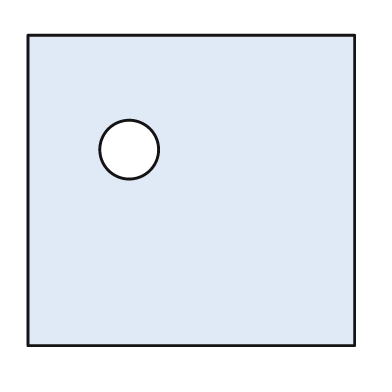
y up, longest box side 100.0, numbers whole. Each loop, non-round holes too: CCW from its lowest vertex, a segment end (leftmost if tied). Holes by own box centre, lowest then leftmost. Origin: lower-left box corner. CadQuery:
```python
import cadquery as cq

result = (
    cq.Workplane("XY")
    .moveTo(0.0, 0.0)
    .lineTo(100.0, 0.0)
    .lineTo(100.0, 95.0)
    .lineTo(0.0, 95.0)
    .close()
    .moveTo(31.0, 60.0)
    .circle(9.0)
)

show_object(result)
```